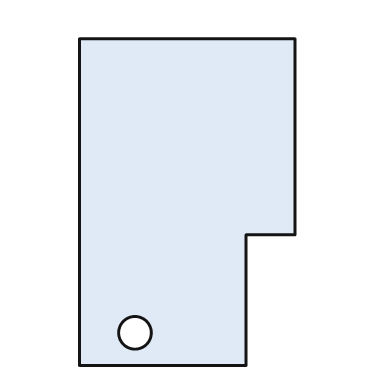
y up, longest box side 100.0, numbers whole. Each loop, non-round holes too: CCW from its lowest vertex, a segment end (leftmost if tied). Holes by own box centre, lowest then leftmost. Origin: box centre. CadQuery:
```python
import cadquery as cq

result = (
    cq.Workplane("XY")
    .moveTo(-33.0, -50.0)
    .lineTo(18.0, -50.0)
    .lineTo(18.0, -10.0)
    .lineTo(33.0, -10.0)
    .lineTo(33.0, 50.0)
    .lineTo(-33.0, 50.0)
    .close()
    .moveTo(-16.0, -40.0)
    .circle(5.0)
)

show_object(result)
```